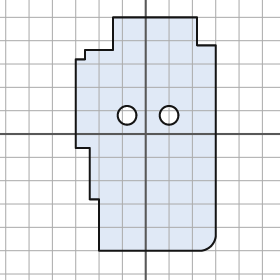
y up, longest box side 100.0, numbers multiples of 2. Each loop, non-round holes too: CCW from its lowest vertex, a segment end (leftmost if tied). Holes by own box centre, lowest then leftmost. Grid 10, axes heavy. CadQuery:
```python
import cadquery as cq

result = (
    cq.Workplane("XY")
    .moveTo(-20.0, -50.0)
    .lineTo(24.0, -50.0)
    .threePointArc((28.0, -48.0), (30.0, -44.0))
    .lineTo(30.0, 38.0)
    .lineTo(22.0, 38.0)
    .lineTo(22.0, 50.0)
    .lineTo(-14.0, 50.0)
    .lineTo(-14.0, 36.0)
    .lineTo(-26.0, 36.0)
    .lineTo(-26.0, 32.0)
    .lineTo(-30.0, 32.0)
    .lineTo(-30.0, -6.0)
    .lineTo(-24.0, -6.0)
    .lineTo(-24.0, -28.0)
    .lineTo(-20.0, -28.0)
    .close()
    .moveTo(-8.0, 8.0)
    .circle(4.0)
    .moveTo(10.0, 8.0)
    .circle(4.0)
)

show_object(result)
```